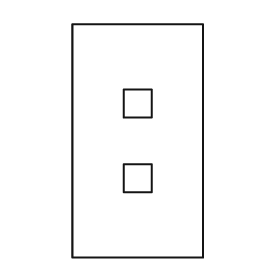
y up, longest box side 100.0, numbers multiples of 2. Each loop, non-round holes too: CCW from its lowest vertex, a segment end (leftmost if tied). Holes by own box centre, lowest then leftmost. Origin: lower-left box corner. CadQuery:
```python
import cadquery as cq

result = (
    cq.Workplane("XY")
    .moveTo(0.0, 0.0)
    .lineTo(56.0, 0.0)
    .lineTo(56.0, 100.0)
    .lineTo(0.0, 100.0)
    .close()
    .moveTo(22.0, 28.0)
    .lineTo(34.0, 28.0)
    .lineTo(34.0, 40.0)
    .lineTo(22.0, 40.0)
    .close()
    .moveTo(22.0, 60.0)
    .lineTo(34.0, 60.0)
    .lineTo(34.0, 72.0)
    .lineTo(22.0, 72.0)
    .close()
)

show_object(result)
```